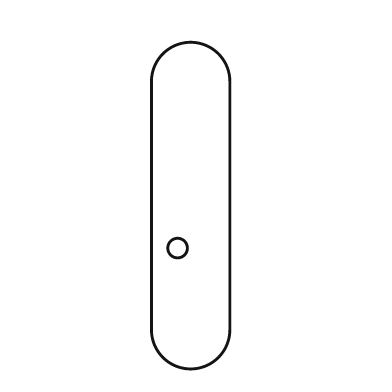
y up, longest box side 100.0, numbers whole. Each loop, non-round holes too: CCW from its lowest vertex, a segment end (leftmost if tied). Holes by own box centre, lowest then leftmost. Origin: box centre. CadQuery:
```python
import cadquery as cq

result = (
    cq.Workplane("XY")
    .moveTo(-12.0, -38.0)
    .threePointArc((0.0, -50.0), (12.0, -38.0))
    .lineTo(12.0, 38.0)
    .threePointArc((0.0, 50.0), (-12.0, 38.0))
    .close()
    .moveTo(-4.0, -13.0)
    .circle(3.0)
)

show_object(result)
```